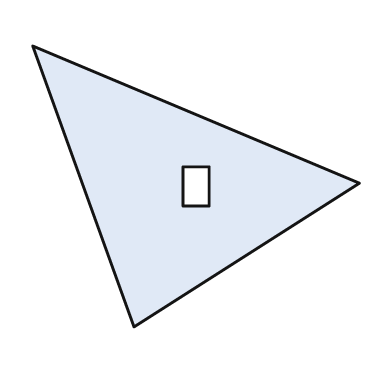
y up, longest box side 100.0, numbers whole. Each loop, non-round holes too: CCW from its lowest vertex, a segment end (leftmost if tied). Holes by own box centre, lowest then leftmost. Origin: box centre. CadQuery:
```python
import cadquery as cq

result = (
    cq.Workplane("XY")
    .moveTo(-19.0, -43.0)
    .lineTo(50.0, 1.0)
    .lineTo(-50.0, 43.0)
    .close()
    .moveTo(-4.0, -6.0)
    .lineTo(4.0, -6.0)
    .lineTo(4.0, 6.0)
    .lineTo(-4.0, 6.0)
    .close()
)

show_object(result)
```